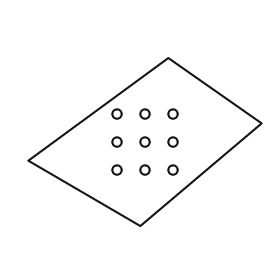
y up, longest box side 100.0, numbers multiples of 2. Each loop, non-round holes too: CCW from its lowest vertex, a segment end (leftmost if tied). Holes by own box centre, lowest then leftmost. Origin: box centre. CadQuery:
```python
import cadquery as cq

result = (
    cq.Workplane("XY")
    .moveTo(-2.0, -36.0)
    .lineTo(50.0, 8.0)
    .lineTo(10.0, 36.0)
    .lineTo(-50.0, -8.0)
    .close()
    .moveTo(-12.0, -12.0)
    .circle(2.0)
    .moveTo(0.0, -12.0)
    .circle(2.0)
    .moveTo(12.0, -12.0)
    .circle(2.0)
    .moveTo(-12.0, 0.0)
    .circle(2.0)
    .moveTo(0.0, 0.0)
    .circle(2.0)
    .moveTo(12.0, 0.0)
    .circle(2.0)
    .moveTo(-12.0, 12.0)
    .circle(2.0)
    .moveTo(0.0, 12.0)
    .circle(2.0)
    .moveTo(12.0, 12.0)
    .circle(2.0)
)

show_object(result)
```